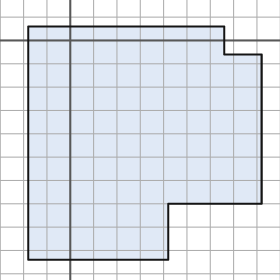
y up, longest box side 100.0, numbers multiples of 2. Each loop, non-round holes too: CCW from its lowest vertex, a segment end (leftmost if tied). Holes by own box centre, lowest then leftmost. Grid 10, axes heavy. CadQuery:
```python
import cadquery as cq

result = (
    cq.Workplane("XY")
    .moveTo(-18.0, -94.0)
    .lineTo(42.0, -94.0)
    .lineTo(42.0, -70.0)
    .lineTo(82.0, -70.0)
    .lineTo(82.0, -6.0)
    .lineTo(66.0, -6.0)
    .lineTo(66.0, 6.0)
    .lineTo(-18.0, 6.0)
    .close()
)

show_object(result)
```